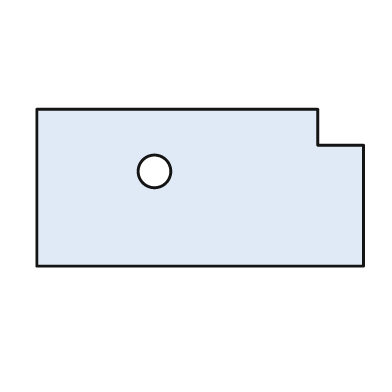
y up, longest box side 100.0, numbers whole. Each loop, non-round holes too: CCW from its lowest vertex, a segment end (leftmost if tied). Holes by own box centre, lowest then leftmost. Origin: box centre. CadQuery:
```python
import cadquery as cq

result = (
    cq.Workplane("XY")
    .moveTo(-50.0, -24.0)
    .lineTo(50.0, -24.0)
    .lineTo(50.0, 13.0)
    .lineTo(36.0, 13.0)
    .lineTo(36.0, 24.0)
    .lineTo(-50.0, 24.0)
    .close()
    .moveTo(-14.0, 5.0)
    .circle(5.0)
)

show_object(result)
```